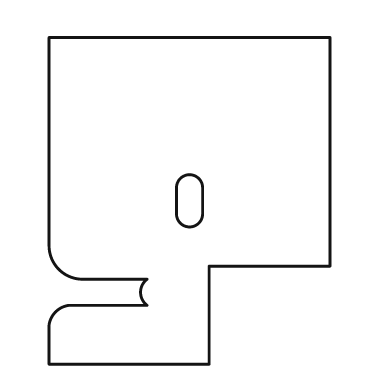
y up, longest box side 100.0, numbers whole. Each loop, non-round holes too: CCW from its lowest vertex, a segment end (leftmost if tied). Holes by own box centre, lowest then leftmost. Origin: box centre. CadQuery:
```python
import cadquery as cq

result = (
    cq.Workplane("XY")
    .moveTo(-43.0, -50.0)
    .lineTo(6.0, -50.0)
    .lineTo(6.0, -20.0)
    .lineTo(43.0, -20.0)
    .lineTo(43.0, 50.0)
    .lineTo(-43.0, 50.0)
    .lineTo(-43.0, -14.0)
    .threePointArc((-40.0, -21.0), (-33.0, -24.0))
    .lineTo(-13.0, -24.0)
    .threePointArc((-15.0, -28.0), (-13.0, -32.0))
    .lineTo(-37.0, -32.0)
    .threePointArc((-41.0, -34.0), (-43.0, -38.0))
    .close()
    .moveTo(-4.0, -4.0)
    .threePointArc((0.0, -8.0), (4.0, -4.0))
    .lineTo(4.0, 4.0)
    .threePointArc((0.0, 8.0), (-4.0, 4.0))
    .close()
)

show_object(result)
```